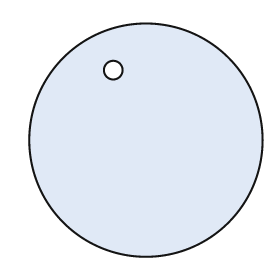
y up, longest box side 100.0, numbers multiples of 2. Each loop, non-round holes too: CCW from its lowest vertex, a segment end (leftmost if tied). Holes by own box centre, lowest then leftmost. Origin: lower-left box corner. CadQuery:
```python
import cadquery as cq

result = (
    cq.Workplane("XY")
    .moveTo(50.0, 50.0)
    .circle(50.0)
    .moveTo(36.0, 80.0)
    .circle(4.0)
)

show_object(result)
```